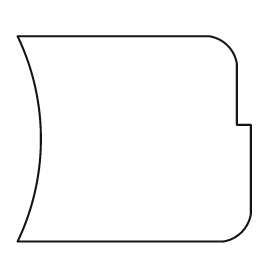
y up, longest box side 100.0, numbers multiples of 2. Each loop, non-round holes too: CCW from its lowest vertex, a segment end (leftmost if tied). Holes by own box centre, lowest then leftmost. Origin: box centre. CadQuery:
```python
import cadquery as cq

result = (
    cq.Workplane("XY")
    .moveTo(-50.0, -44.0)
    .lineTo(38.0, -44.0)
    .threePointArc((46.0, -40.0), (50.0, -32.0))
    .lineTo(50.0, 6.0)
    .lineTo(44.0, 6.0)
    .lineTo(44.0, 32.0)
    .threePointArc((40.0, 40.0), (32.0, 44.0))
    .lineTo(-50.0, 44.0)
    .threePointArc((-40.0, 0.0), (-50.0, -44.0))
    .close()
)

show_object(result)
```